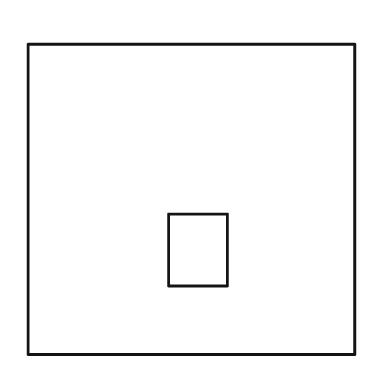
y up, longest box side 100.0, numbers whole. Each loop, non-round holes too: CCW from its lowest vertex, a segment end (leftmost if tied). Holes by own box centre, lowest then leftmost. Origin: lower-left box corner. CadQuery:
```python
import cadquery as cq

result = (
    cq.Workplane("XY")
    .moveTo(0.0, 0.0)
    .lineTo(100.0, 0.0)
    .lineTo(100.0, 95.0)
    .lineTo(0.0, 95.0)
    .close()
    .moveTo(43.0, 21.0)
    .lineTo(61.0, 21.0)
    .lineTo(61.0, 43.0)
    .lineTo(43.0, 43.0)
    .close()
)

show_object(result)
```